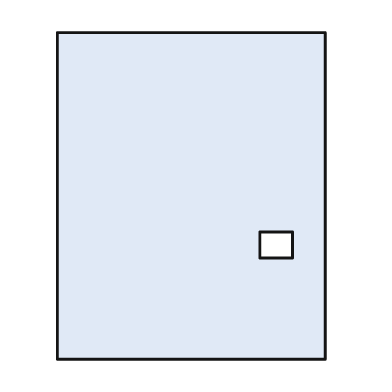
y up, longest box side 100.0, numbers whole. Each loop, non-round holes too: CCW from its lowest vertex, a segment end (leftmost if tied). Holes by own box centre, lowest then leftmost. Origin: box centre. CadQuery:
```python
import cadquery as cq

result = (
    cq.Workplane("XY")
    .moveTo(-41.0, -50.0)
    .lineTo(41.0, -50.0)
    .lineTo(41.0, 50.0)
    .lineTo(-41.0, 50.0)
    .close()
    .moveTo(21.0, -19.0)
    .lineTo(31.0, -19.0)
    .lineTo(31.0, -11.0)
    .lineTo(21.0, -11.0)
    .close()
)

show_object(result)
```